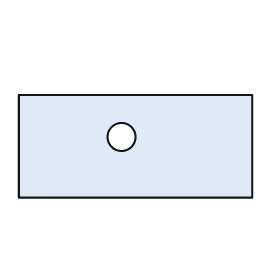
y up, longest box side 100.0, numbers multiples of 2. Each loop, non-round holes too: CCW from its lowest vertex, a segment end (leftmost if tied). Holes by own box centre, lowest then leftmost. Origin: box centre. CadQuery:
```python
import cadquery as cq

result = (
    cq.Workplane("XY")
    .moveTo(-50.0, -22.0)
    .lineTo(50.0, -22.0)
    .lineTo(50.0, 22.0)
    .lineTo(-50.0, 22.0)
    .close()
    .moveTo(-6.0, 4.0)
    .circle(6.0)
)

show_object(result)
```